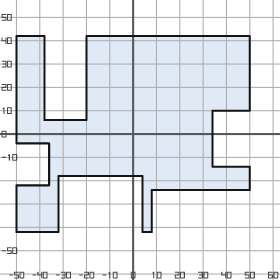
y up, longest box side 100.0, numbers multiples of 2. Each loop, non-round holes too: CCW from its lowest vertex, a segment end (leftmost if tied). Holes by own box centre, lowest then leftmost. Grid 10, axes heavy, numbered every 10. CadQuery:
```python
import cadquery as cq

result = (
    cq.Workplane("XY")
    .moveTo(-50.0, -42.0)
    .lineTo(-32.0, -42.0)
    .lineTo(-32.0, -18.0)
    .lineTo(4.0, -18.0)
    .lineTo(4.0, -42.0)
    .lineTo(8.0, -42.0)
    .lineTo(8.0, -24.0)
    .lineTo(50.0, -24.0)
    .lineTo(50.0, -14.0)
    .lineTo(34.0, -14.0)
    .lineTo(34.0, 10.0)
    .lineTo(50.0, 10.0)
    .lineTo(50.0, 42.0)
    .lineTo(-20.0, 42.0)
    .lineTo(-20.0, 6.0)
    .lineTo(-38.0, 6.0)
    .lineTo(-38.0, 42.0)
    .lineTo(-50.0, 42.0)
    .lineTo(-50.0, -4.0)
    .lineTo(-36.0, -4.0)
    .lineTo(-36.0, -22.0)
    .lineTo(-50.0, -22.0)
    .close()
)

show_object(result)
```